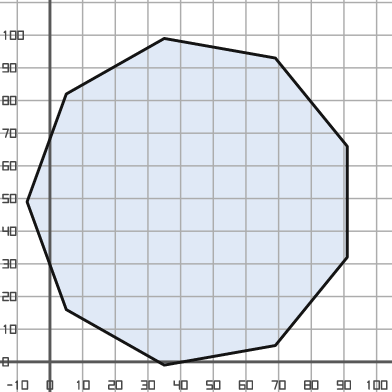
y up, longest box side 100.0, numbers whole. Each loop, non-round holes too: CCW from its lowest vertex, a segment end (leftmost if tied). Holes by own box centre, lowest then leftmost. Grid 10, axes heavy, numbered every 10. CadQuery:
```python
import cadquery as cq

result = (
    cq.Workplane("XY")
    .moveTo(35.0, -1.0)
    .lineTo(69.0, 5.0)
    .lineTo(91.0, 32.0)
    .lineTo(91.0, 66.0)
    .lineTo(69.0, 93.0)
    .lineTo(35.0, 99.0)
    .lineTo(5.0, 82.0)
    .lineTo(-7.0, 49.0)
    .lineTo(5.0, 16.0)
    .close()
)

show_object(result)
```